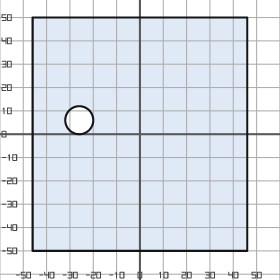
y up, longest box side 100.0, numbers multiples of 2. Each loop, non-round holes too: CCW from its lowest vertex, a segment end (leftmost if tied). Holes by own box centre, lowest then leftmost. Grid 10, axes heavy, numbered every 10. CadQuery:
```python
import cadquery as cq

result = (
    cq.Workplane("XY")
    .moveTo(-46.0, -50.0)
    .lineTo(46.0, -50.0)
    .lineTo(46.0, 50.0)
    .lineTo(-46.0, 50.0)
    .close()
    .moveTo(-26.0, 6.0)
    .circle(6.0)
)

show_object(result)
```